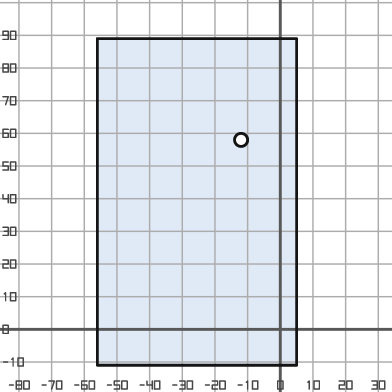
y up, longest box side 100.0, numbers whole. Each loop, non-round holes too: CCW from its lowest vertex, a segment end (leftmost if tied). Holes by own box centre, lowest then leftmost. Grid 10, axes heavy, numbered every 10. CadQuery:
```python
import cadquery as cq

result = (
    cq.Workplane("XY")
    .moveTo(-56.0, -11.0)
    .lineTo(5.0, -11.0)
    .lineTo(5.0, 89.0)
    .lineTo(-56.0, 89.0)
    .close()
    .moveTo(-12.0, 58.0)
    .circle(2.0)
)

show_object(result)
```